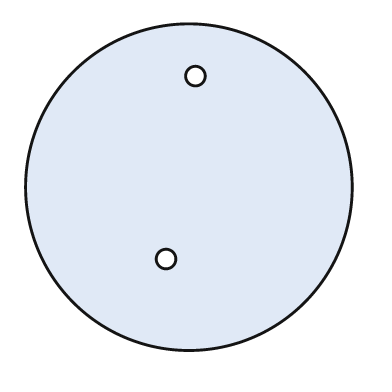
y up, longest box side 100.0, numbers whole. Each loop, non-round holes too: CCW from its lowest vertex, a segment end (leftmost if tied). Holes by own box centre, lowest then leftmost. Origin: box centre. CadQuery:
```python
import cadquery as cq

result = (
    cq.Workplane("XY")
    .moveTo(0.0, 0.0)
    .circle(50.0)
    .moveTo(-7.0, -22.0)
    .circle(3.0)
    .moveTo(2.0, 34.0)
    .circle(3.0)
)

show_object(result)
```